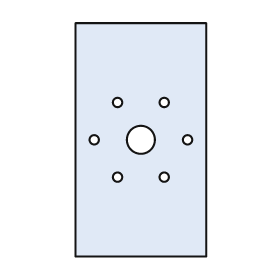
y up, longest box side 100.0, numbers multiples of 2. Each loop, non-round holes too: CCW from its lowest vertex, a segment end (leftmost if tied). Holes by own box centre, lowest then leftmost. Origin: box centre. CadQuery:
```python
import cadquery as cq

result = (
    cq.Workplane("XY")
    .moveTo(-28.0, -50.0)
    .lineTo(28.0, -50.0)
    .lineTo(28.0, 50.0)
    .lineTo(-28.0, 50.0)
    .close()
    .moveTo(-10.0, -16.0)
    .circle(2.0)
    .moveTo(10.0, -16.0)
    .circle(2.0)
    .moveTo(-20.0, 0.0)
    .circle(2.0)
    .moveTo(0.0, 0.0)
    .circle(6.0)
    .moveTo(20.0, 0.0)
    .circle(2.0)
    .moveTo(-10.0, 16.0)
    .circle(2.0)
    .moveTo(10.0, 16.0)
    .circle(2.0)
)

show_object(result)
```